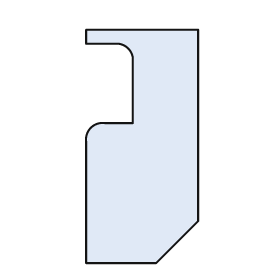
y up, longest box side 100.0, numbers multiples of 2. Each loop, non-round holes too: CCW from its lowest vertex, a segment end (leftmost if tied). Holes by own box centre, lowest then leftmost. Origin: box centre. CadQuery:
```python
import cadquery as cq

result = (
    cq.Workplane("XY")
    .moveTo(-24.0, -50.0)
    .lineTo(6.0, -50.0)
    .lineTo(24.0, -32.0)
    .lineTo(24.0, 50.0)
    .lineTo(-24.0, 50.0)
    .lineTo(-24.0, 44.0)
    .lineTo(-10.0, 44.0)
    .threePointArc((-6.0, 42.0), (-4.0, 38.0))
    .lineTo(-4.0, 10.0)
    .lineTo(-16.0, 10.0)
    .threePointArc((-22.0, 8.0), (-24.0, 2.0))
    .close()
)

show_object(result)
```